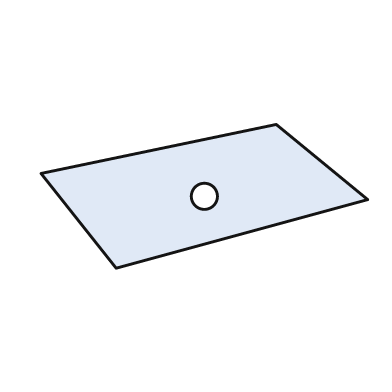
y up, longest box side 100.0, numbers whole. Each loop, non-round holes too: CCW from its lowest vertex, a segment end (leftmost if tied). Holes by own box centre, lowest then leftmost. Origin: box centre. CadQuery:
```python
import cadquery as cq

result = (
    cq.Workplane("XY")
    .moveTo(-27.0, -22.0)
    .lineTo(50.0, -1.0)
    .lineTo(22.0, 22.0)
    .lineTo(-50.0, 7.0)
    .close()
    .moveTo(0.0, 0.0)
    .circle(4.0)
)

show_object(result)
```